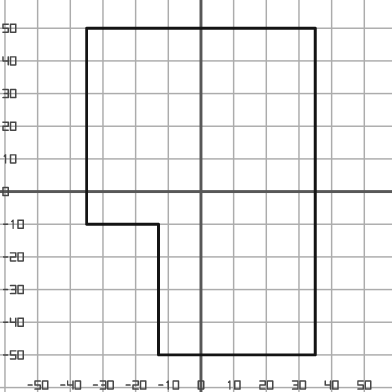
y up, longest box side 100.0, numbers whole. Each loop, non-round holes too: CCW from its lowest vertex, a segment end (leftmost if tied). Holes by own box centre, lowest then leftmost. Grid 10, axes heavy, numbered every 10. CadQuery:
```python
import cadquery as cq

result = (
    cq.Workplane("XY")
    .moveTo(-13.0, -50.0)
    .lineTo(35.0, -50.0)
    .lineTo(35.0, 50.0)
    .lineTo(-35.0, 50.0)
    .lineTo(-35.0, -10.0)
    .lineTo(-13.0, -10.0)
    .close()
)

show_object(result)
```